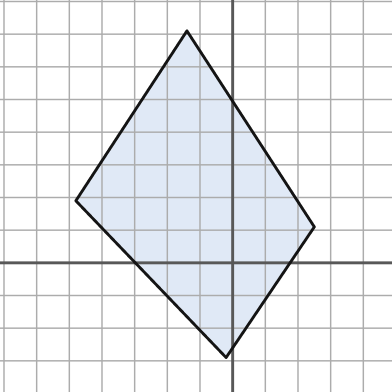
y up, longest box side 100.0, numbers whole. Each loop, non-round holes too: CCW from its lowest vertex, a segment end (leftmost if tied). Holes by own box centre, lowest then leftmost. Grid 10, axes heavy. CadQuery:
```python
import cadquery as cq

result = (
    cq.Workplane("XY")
    .moveTo(-2.0, -29.0)
    .lineTo(25.0, 11.0)
    .lineTo(-14.0, 71.0)
    .lineTo(-48.0, 19.0)
    .close()
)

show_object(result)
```